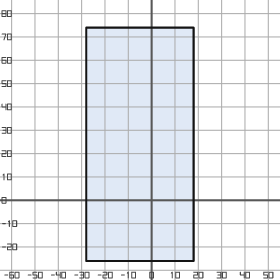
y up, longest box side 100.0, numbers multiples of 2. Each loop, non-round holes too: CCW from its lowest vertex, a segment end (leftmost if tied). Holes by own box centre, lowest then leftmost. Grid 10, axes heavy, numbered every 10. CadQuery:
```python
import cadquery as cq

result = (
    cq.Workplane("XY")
    .moveTo(-28.0, -26.0)
    .lineTo(18.0, -26.0)
    .lineTo(18.0, 74.0)
    .lineTo(-28.0, 74.0)
    .close()
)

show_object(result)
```